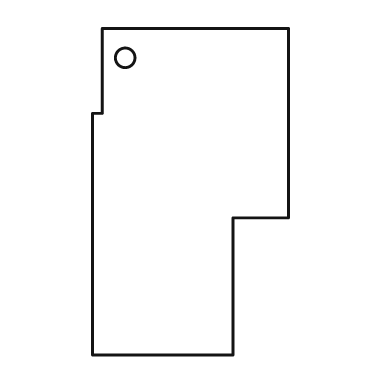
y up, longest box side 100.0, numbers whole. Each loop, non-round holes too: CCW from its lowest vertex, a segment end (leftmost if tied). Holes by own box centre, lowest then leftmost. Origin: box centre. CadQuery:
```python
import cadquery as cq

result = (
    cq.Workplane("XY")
    .moveTo(-30.0, -50.0)
    .lineTo(13.0, -50.0)
    .lineTo(13.0, -8.0)
    .lineTo(30.0, -8.0)
    .lineTo(30.0, 50.0)
    .lineTo(-27.0, 50.0)
    .lineTo(-27.0, 24.0)
    .lineTo(-30.0, 24.0)
    .close()
    .moveTo(-20.0, 41.0)
    .circle(3.0)
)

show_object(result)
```